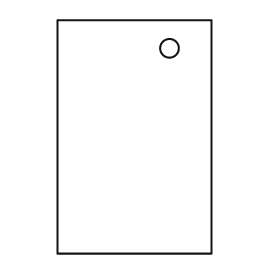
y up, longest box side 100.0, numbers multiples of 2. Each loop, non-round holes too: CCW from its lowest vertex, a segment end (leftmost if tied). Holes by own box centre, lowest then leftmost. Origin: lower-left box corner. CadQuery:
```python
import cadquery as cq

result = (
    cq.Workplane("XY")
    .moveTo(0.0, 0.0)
    .lineTo(66.0, 0.0)
    .lineTo(66.0, 100.0)
    .lineTo(0.0, 100.0)
    .close()
    .moveTo(48.0, 88.0)
    .circle(4.0)
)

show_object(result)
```